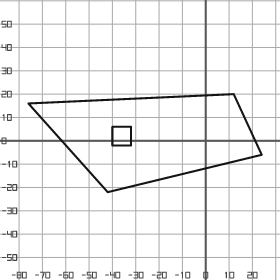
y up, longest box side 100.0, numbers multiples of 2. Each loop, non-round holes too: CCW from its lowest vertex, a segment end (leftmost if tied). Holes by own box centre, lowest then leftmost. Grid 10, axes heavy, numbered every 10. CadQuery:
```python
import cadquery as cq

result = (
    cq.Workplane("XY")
    .moveTo(-42.0, -22.0)
    .lineTo(24.0, -6.0)
    .lineTo(12.0, 20.0)
    .lineTo(-76.0, 16.0)
    .close()
    .moveTo(-40.0, -2.0)
    .lineTo(-32.0, -2.0)
    .lineTo(-32.0, 6.0)
    .lineTo(-40.0, 6.0)
    .close()
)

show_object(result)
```